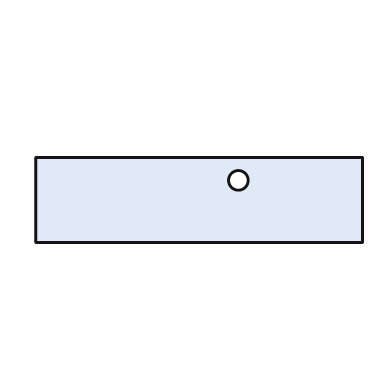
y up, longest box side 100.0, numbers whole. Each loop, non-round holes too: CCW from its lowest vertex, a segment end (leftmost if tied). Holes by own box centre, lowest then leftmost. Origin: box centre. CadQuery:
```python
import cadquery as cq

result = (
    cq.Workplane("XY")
    .moveTo(-50.0, -13.0)
    .lineTo(50.0, -13.0)
    .lineTo(50.0, 13.0)
    .lineTo(-50.0, 13.0)
    .close()
    .moveTo(12.0, 6.0)
    .circle(3.0)
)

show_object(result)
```